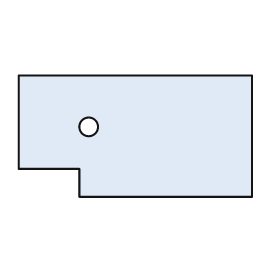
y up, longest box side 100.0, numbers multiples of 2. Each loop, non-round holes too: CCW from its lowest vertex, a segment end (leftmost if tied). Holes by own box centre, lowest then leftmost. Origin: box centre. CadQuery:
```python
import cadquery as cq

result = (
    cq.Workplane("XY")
    .moveTo(-24.0, -26.0)
    .lineTo(50.0, -26.0)
    .lineTo(50.0, 26.0)
    .lineTo(-50.0, 26.0)
    .lineTo(-50.0, -14.0)
    .lineTo(-24.0, -14.0)
    .close()
    .moveTo(-20.0, 4.0)
    .circle(4.0)
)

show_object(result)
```